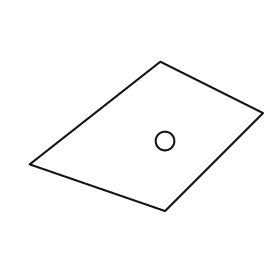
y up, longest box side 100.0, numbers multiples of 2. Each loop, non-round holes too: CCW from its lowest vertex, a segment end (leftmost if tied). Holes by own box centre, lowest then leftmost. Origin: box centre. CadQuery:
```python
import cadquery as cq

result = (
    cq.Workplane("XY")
    .moveTo(8.0, -32.0)
    .lineTo(50.0, 10.0)
    .lineTo(6.0, 32.0)
    .lineTo(-50.0, -12.0)
    .close()
    .moveTo(8.0, -2.0)
    .circle(4.0)
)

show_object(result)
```